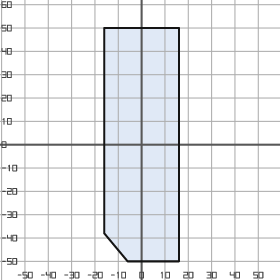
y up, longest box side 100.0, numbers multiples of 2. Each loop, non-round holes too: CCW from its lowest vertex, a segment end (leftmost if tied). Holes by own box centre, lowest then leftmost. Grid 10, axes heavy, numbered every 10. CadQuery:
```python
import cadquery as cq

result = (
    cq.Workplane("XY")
    .moveTo(-6.0, -50.0)
    .lineTo(16.0, -50.0)
    .lineTo(16.0, 50.0)
    .lineTo(-16.0, 50.0)
    .lineTo(-16.0, -38.0)
    .close()
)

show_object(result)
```